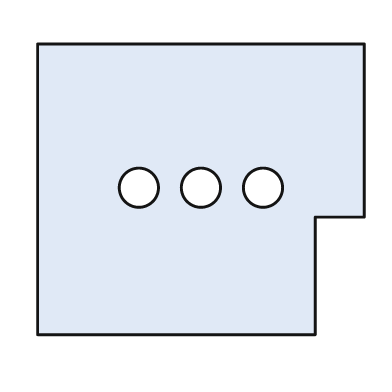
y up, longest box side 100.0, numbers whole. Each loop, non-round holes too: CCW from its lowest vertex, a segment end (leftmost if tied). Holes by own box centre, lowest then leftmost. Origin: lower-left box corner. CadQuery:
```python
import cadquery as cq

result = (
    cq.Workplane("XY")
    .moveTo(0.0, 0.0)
    .lineTo(85.0, 0.0)
    .lineTo(85.0, 36.0)
    .lineTo(100.0, 36.0)
    .lineTo(100.0, 89.0)
    .lineTo(0.0, 89.0)
    .close()
    .moveTo(31.0, 45.0)
    .circle(6.0)
    .moveTo(50.0, 45.0)
    .circle(6.0)
    .moveTo(69.0, 45.0)
    .circle(6.0)
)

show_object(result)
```